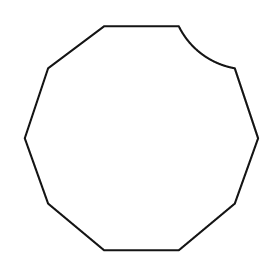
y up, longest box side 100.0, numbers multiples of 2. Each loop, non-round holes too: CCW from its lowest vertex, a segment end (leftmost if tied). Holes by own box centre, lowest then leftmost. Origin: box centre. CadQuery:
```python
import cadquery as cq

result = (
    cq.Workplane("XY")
    .moveTo(-16.0, -48.0)
    .lineTo(16.0, -48.0)
    .lineTo(40.0, -28.0)
    .lineTo(50.0, 0.0)
    .lineTo(40.0, 30.0)
    .threePointArc((26.0, 36.0), (16.0, 48.0))
    .lineTo(-16.0, 48.0)
    .lineTo(-40.0, 30.0)
    .lineTo(-50.0, 0.0)
    .lineTo(-40.0, -28.0)
    .close()
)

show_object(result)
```